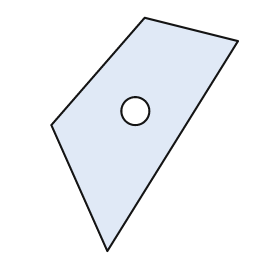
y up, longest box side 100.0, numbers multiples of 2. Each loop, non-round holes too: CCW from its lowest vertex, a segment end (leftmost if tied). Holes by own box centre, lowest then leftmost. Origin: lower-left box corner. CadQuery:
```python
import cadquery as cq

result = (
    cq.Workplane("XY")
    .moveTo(24.0, 0.0)
    .lineTo(80.0, 90.0)
    .lineTo(40.0, 100.0)
    .lineTo(0.0, 54.0)
    .close()
    .moveTo(36.0, 60.0)
    .circle(6.0)
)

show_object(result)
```